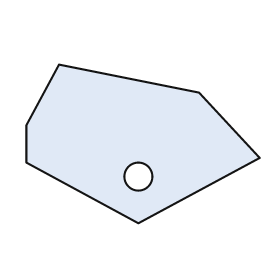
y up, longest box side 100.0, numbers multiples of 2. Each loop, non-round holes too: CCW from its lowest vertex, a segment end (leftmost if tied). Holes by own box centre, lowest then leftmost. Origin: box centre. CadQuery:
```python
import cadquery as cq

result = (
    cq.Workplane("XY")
    .moveTo(-2.0, -34.0)
    .lineTo(50.0, -6.0)
    .lineTo(24.0, 22.0)
    .lineTo(-36.0, 34.0)
    .lineTo(-50.0, 8.0)
    .lineTo(-50.0, -8.0)
    .close()
    .moveTo(-2.0, -14.0)
    .circle(6.0)
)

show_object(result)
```